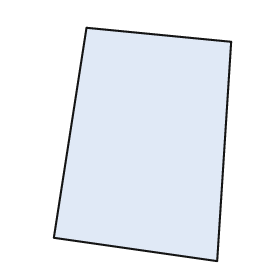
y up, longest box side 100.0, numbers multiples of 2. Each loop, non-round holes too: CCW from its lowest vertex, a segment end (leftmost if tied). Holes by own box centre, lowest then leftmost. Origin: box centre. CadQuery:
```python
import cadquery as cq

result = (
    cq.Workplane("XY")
    .moveTo(32.0, -50.0)
    .lineTo(38.0, 44.0)
    .lineTo(-24.0, 50.0)
    .lineTo(-38.0, -40.0)
    .close()
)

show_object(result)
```